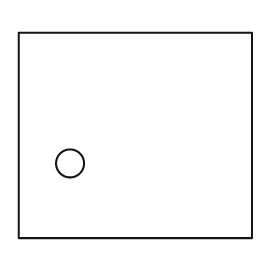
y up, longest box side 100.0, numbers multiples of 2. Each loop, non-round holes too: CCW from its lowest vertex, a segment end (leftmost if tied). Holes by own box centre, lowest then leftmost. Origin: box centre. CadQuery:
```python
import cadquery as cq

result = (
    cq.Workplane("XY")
    .moveTo(-50.0, -44.0)
    .lineTo(50.0, -44.0)
    .lineTo(50.0, 44.0)
    .lineTo(-50.0, 44.0)
    .close()
    .moveTo(-28.0, -12.0)
    .circle(6.0)
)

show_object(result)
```